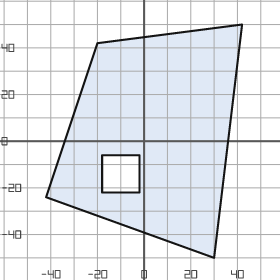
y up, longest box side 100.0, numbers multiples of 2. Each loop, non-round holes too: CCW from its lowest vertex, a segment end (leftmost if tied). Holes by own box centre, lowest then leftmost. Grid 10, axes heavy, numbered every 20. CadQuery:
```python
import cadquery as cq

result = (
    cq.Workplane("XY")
    .moveTo(30.0, -50.0)
    .lineTo(42.0, 50.0)
    .lineTo(-20.0, 42.0)
    .lineTo(-42.0, -24.0)
    .close()
    .moveTo(-18.0, -22.0)
    .lineTo(-2.0, -22.0)
    .lineTo(-2.0, -6.0)
    .lineTo(-18.0, -6.0)
    .close()
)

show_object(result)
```